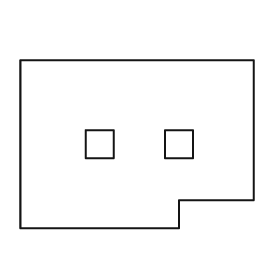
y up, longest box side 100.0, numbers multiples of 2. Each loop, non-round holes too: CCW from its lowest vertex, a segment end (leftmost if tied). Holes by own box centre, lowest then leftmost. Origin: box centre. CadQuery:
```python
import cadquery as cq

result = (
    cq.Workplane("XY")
    .moveTo(-50.0, -36.0)
    .lineTo(18.0, -36.0)
    .lineTo(18.0, -24.0)
    .lineTo(50.0, -24.0)
    .lineTo(50.0, 36.0)
    .lineTo(-50.0, 36.0)
    .close()
    .moveTo(-22.0, -6.0)
    .lineTo(-10.0, -6.0)
    .lineTo(-10.0, 6.0)
    .lineTo(-22.0, 6.0)
    .close()
    .moveTo(12.0, -6.0)
    .lineTo(24.0, -6.0)
    .lineTo(24.0, 6.0)
    .lineTo(12.0, 6.0)
    .close()
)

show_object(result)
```